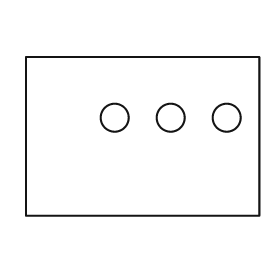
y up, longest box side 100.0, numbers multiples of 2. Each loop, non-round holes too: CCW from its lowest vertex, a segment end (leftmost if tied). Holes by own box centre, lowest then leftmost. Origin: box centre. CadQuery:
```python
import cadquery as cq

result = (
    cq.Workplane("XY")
    .moveTo(-50.0, -34.0)
    .lineTo(50.0, -34.0)
    .lineTo(50.0, 34.0)
    .lineTo(-50.0, 34.0)
    .close()
    .moveTo(-12.0, 8.0)
    .circle(6.0)
    .moveTo(12.0, 8.0)
    .circle(6.0)
    .moveTo(36.0, 8.0)
    .circle(6.0)
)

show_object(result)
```